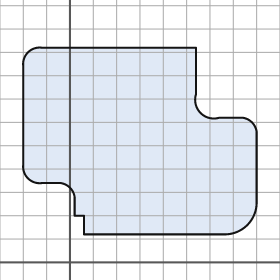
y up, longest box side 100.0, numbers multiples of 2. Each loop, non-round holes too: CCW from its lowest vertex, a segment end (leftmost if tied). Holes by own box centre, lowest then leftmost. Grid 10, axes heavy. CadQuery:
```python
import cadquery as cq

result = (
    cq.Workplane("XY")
    .moveTo(6.0, 12.0)
    .lineTo(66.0, 12.0)
    .threePointArc((76.0, 16.0), (80.0, 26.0))
    .lineTo(80.0, 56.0)
    .threePointArc((78.0, 60.0), (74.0, 62.0))
    .lineTo(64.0, 62.0)
    .threePointArc((56.0, 64.0), (54.0, 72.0))
    .lineTo(54.0, 92.0)
    .lineTo(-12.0, 92.0)
    .threePointArc((-18.0, 90.0), (-20.0, 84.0))
    .lineTo(-20.0, 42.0)
    .threePointArc((-18.0, 36.0), (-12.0, 34.0))
    .lineTo(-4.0, 34.0)
    .threePointArc((0.0, 32.0), (2.0, 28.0))
    .lineTo(2.0, 20.0)
    .lineTo(6.0, 20.0)
    .close()
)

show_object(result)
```